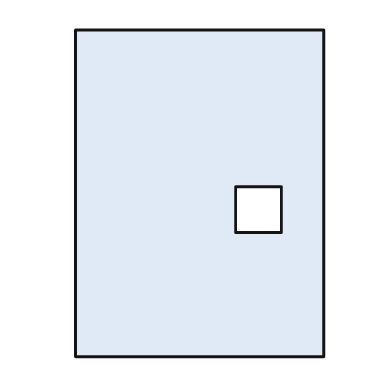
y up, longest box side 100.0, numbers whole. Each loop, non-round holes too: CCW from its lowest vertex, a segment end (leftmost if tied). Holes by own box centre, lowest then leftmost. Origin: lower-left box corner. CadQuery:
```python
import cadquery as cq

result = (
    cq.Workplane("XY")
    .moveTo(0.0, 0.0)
    .lineTo(76.0, 0.0)
    .lineTo(76.0, 100.0)
    .lineTo(0.0, 100.0)
    .close()
    .moveTo(49.0, 38.0)
    .lineTo(63.0, 38.0)
    .lineTo(63.0, 52.0)
    .lineTo(49.0, 52.0)
    .close()
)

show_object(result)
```